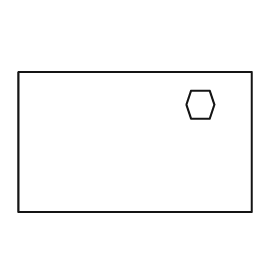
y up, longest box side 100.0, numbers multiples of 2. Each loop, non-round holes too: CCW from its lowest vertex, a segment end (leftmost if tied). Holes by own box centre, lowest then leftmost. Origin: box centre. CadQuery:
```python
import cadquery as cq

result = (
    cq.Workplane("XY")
    .moveTo(-50.0, -30.0)
    .lineTo(50.0, -30.0)
    .lineTo(50.0, 30.0)
    .lineTo(-50.0, 30.0)
    .close()
    .moveTo(24.0, 10.0)
    .lineTo(32.0, 10.0)
    .lineTo(34.0, 16.0)
    .lineTo(32.0, 22.0)
    .lineTo(24.0, 22.0)
    .lineTo(22.0, 16.0)
    .close()
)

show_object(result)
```